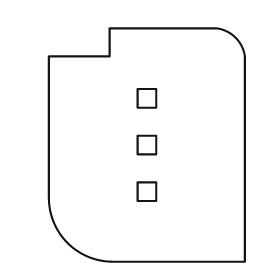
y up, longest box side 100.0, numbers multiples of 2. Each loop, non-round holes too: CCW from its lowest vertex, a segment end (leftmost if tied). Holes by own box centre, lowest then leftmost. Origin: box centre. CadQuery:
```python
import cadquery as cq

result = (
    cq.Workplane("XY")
    .moveTo(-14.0, -50.0)
    .lineTo(42.0, -50.0)
    .lineTo(42.0, 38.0)
    .threePointArc((38.0, 46.0), (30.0, 50.0))
    .lineTo(-16.0, 50.0)
    .lineTo(-16.0, 38.0)
    .lineTo(-42.0, 38.0)
    .lineTo(-42.0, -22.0)
    .threePointArc((-34.0, -42.0), (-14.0, -50.0))
    .close()
    .moveTo(-4.0, -24.0)
    .lineTo(4.0, -24.0)
    .lineTo(4.0, -16.0)
    .lineTo(-4.0, -16.0)
    .close()
    .moveTo(-4.0, -4.0)
    .lineTo(4.0, -4.0)
    .lineTo(4.0, 4.0)
    .lineTo(-4.0, 4.0)
    .close()
    .moveTo(-4.0, 16.0)
    .lineTo(4.0, 16.0)
    .lineTo(4.0, 24.0)
    .lineTo(-4.0, 24.0)
    .close()
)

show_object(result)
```